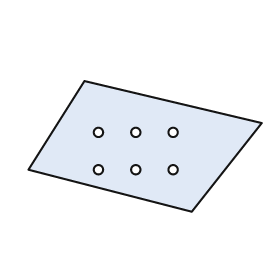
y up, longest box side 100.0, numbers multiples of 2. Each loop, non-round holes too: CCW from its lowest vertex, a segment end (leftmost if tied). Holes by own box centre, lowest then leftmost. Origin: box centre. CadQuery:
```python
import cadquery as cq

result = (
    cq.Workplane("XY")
    .moveTo(20.0, -28.0)
    .lineTo(50.0, 10.0)
    .lineTo(-26.0, 28.0)
    .lineTo(-50.0, -10.0)
    .close()
    .moveTo(-20.0, -10.0)
    .circle(2.0)
    .moveTo(-4.0, -10.0)
    .circle(2.0)
    .moveTo(12.0, -10.0)
    .circle(2.0)
    .moveTo(-20.0, 6.0)
    .circle(2.0)
    .moveTo(-4.0, 6.0)
    .circle(2.0)
    .moveTo(12.0, 6.0)
    .circle(2.0)
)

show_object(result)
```